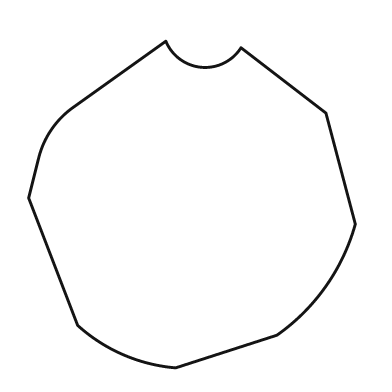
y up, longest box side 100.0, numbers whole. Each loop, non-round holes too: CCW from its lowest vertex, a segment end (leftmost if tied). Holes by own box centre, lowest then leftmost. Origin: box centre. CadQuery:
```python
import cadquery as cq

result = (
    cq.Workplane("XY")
    .moveTo(-5.0, -50.0)
    .lineTo(26.0, -40.0)
    .threePointArc((41.0, -25.0), (50.0, -6.0))
    .lineTo(41.0, 28.0)
    .lineTo(15.0, 48.0)
    .threePointArc((3.0, 42.0), (-8.0, 50.0))
    .lineTo(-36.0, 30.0)
    .threePointArc((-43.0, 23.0), (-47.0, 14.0))
    .lineTo(-50.0, 2.0)
    .lineTo(-35.0, -37.0)
    .threePointArc((-21.0, -46.0), (-5.0, -50.0))
    .close()
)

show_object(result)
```